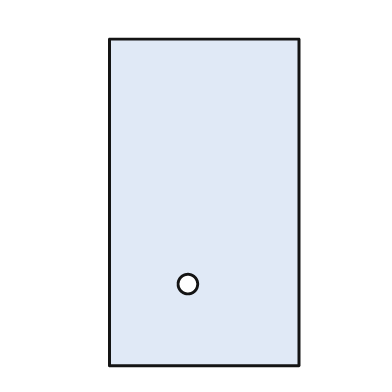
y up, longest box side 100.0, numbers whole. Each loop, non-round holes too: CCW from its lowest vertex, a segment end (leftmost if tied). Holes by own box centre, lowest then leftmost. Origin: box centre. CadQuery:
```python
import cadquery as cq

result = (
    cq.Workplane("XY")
    .moveTo(-29.0, -50.0)
    .lineTo(29.0, -50.0)
    .lineTo(29.0, 50.0)
    .lineTo(-29.0, 50.0)
    .close()
    .moveTo(-5.0, -25.0)
    .circle(3.0)
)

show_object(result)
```